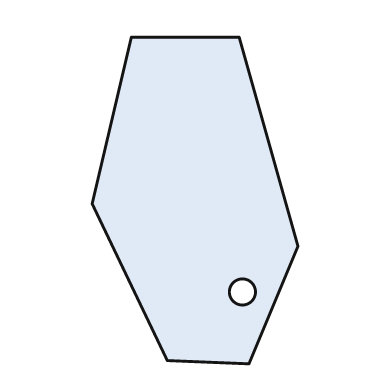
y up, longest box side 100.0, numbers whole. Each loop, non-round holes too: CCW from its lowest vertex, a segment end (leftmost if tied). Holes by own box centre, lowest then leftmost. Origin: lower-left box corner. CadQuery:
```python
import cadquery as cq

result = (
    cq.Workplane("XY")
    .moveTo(48.0, 0.0)
    .lineTo(63.0, 36.0)
    .lineTo(45.0, 100.0)
    .lineTo(12.0, 100.0)
    .lineTo(0.0, 49.0)
    .lineTo(23.0, 1.0)
    .close()
    .moveTo(46.0, 22.0)
    .circle(4.0)
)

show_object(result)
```